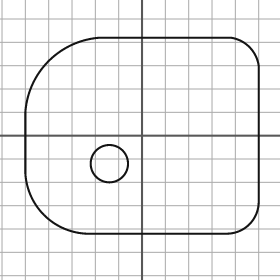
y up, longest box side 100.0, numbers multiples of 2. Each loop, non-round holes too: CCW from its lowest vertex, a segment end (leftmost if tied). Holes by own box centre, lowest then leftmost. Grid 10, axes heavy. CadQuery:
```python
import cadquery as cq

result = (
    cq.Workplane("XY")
    .moveTo(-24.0, -42.0)
    .lineTo(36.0, -42.0)
    .threePointArc((46.0, -38.0), (50.0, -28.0))
    .lineTo(50.0, 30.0)
    .threePointArc((46.0, 38.0), (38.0, 42.0))
    .lineTo(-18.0, 42.0)
    .threePointArc((-40.0, 32.0), (-50.0, 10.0))
    .lineTo(-50.0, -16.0)
    .threePointArc((-42.0, -34.0), (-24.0, -42.0))
    .close()
    .moveTo(-14.0, -12.0)
    .circle(8.0)
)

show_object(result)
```